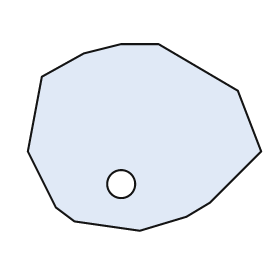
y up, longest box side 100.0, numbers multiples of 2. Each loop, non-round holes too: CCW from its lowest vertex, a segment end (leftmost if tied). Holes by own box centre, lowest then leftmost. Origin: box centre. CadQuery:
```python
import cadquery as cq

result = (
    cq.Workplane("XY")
    .moveTo(-2.0, -40.0)
    .lineTo(18.0, -34.0)
    .lineTo(28.0, -28.0)
    .lineTo(50.0, -6.0)
    .lineTo(40.0, 20.0)
    .lineTo(6.0, 40.0)
    .lineTo(-10.0, 40.0)
    .lineTo(-26.0, 36.0)
    .lineTo(-44.0, 26.0)
    .lineTo(-50.0, -6.0)
    .lineTo(-38.0, -30.0)
    .lineTo(-30.0, -36.0)
    .close()
    .moveTo(-10.0, -20.0)
    .circle(6.0)
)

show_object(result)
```